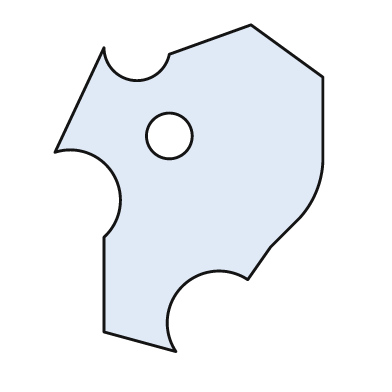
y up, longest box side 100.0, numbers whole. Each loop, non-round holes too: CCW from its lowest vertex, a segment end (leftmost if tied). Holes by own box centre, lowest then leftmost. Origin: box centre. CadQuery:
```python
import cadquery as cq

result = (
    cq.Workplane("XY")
    .moveTo(-4.0, -50.0)
    .threePointArc((-2.0, -30.0), (18.0, -28.0))
    .lineTo(25.0, -18.0)
    .lineTo(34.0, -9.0)
    .threePointArc((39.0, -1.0), (41.0, 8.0))
    .lineTo(41.0, 34.0)
    .lineTo(19.0, 50.0)
    .lineTo(-6.0, 41.0)
    .threePointArc((-17.0, 33.0), (-26.0, 43.0))
    .lineTo(-41.0, 11.0)
    .threePointArc((-23.0, 4.0), (-26.0, -15.0))
    .lineTo(-26.0, -44.0)
    .close()
    .moveTo(-6.0, 16.0)
    .circle(7.0)
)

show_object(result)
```